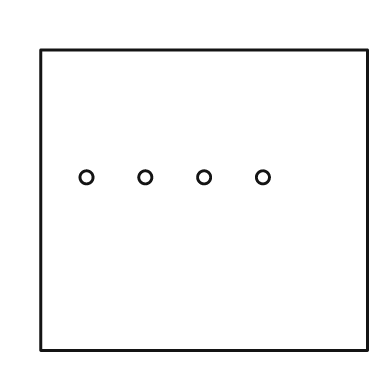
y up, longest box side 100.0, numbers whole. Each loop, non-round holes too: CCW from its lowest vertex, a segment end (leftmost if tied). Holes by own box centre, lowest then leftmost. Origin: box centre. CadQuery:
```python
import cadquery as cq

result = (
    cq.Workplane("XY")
    .moveTo(-50.0, -46.0)
    .lineTo(50.0, -46.0)
    .lineTo(50.0, 46.0)
    .lineTo(-50.0, 46.0)
    .close()
    .moveTo(-36.0, 7.0)
    .circle(2.0)
    .moveTo(-18.0, 7.0)
    .circle(2.0)
    .moveTo(0.0, 7.0)
    .circle(2.0)
    .moveTo(18.0, 7.0)
    .circle(2.0)
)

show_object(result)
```